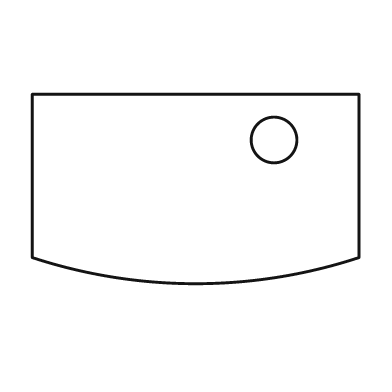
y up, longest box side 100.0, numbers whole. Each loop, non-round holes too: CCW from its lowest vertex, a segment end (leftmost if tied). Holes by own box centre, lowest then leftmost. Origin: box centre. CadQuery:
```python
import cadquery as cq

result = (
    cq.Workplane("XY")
    .moveTo(-50.0, -21.0)
    .threePointArc((0.0, -29.0), (50.0, -21.0))
    .lineTo(50.0, 29.0)
    .lineTo(-50.0, 29.0)
    .close()
    .moveTo(24.0, 15.0)
    .circle(7.0)
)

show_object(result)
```